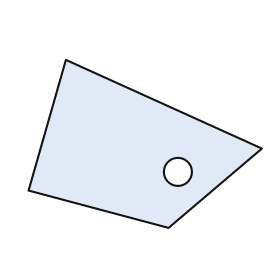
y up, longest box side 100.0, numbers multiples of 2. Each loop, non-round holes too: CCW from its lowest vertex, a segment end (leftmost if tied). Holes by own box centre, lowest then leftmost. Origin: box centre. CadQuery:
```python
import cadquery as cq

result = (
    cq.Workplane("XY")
    .moveTo(10.0, -36.0)
    .lineTo(50.0, -2.0)
    .lineTo(-34.0, 36.0)
    .lineTo(-50.0, -20.0)
    .close()
    .moveTo(14.0, -12.0)
    .circle(6.0)
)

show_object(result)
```